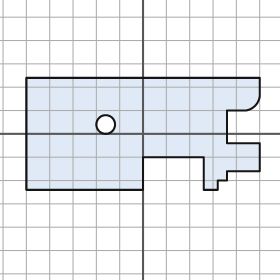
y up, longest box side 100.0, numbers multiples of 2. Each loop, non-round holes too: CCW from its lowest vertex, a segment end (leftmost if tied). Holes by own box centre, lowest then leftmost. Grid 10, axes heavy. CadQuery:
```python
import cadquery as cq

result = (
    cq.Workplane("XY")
    .moveTo(-50.0, -24.0)
    .lineTo(0.0, -24.0)
    .lineTo(0.0, -10.0)
    .lineTo(26.0, -10.0)
    .lineTo(26.0, -24.0)
    .lineTo(32.0, -24.0)
    .lineTo(32.0, -20.0)
    .lineTo(36.0, -20.0)
    .lineTo(36.0, -16.0)
    .lineTo(50.0, -16.0)
    .lineTo(50.0, -4.0)
    .lineTo(36.0, -4.0)
    .lineTo(36.0, 10.0)
    .lineTo(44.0, 10.0)
    .threePointArc((48.0, 12.0), (50.0, 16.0))
    .lineTo(50.0, 24.0)
    .lineTo(-50.0, 24.0)
    .close()
    .moveTo(-16.0, 4.0)
    .circle(4.0)
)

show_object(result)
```